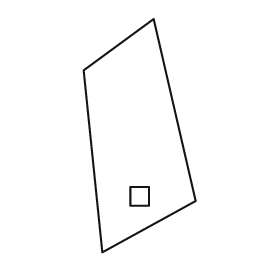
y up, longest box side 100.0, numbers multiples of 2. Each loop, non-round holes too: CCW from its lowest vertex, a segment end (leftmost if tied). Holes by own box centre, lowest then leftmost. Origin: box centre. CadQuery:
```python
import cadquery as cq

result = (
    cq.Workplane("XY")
    .moveTo(-16.0, -50.0)
    .lineTo(24.0, -28.0)
    .lineTo(6.0, 50.0)
    .lineTo(-24.0, 28.0)
    .close()
    .moveTo(-4.0, -30.0)
    .lineTo(4.0, -30.0)
    .lineTo(4.0, -22.0)
    .lineTo(-4.0, -22.0)
    .close()
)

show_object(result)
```